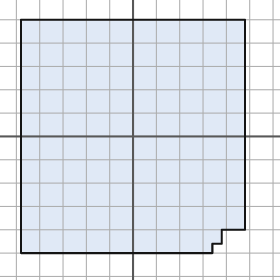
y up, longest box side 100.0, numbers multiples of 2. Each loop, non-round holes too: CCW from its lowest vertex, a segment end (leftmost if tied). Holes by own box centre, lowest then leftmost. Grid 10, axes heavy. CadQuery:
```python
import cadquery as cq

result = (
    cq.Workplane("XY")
    .moveTo(-48.0, -50.0)
    .lineTo(34.0, -50.0)
    .lineTo(34.0, -46.0)
    .lineTo(38.0, -46.0)
    .lineTo(38.0, -40.0)
    .lineTo(48.0, -40.0)
    .lineTo(48.0, 50.0)
    .lineTo(-48.0, 50.0)
    .close()
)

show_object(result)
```